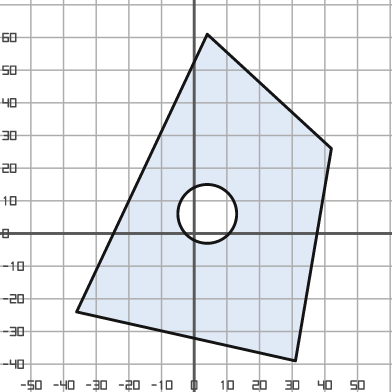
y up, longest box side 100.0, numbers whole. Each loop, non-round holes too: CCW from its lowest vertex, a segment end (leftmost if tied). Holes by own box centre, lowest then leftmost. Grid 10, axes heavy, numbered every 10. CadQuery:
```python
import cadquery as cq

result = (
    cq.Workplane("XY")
    .moveTo(31.0, -39.0)
    .lineTo(42.0, 26.0)
    .lineTo(4.0, 61.0)
    .lineTo(-36.0, -24.0)
    .close()
    .moveTo(4.0, 6.0)
    .circle(9.0)
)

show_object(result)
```